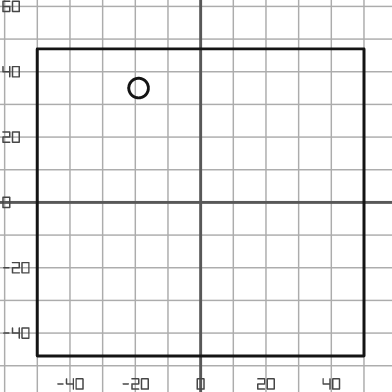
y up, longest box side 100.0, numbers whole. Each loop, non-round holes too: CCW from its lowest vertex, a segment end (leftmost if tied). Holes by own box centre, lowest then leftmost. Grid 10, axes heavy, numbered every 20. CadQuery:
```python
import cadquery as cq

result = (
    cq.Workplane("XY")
    .moveTo(-50.0, -47.0)
    .lineTo(50.0, -47.0)
    .lineTo(50.0, 47.0)
    .lineTo(-50.0, 47.0)
    .close()
    .moveTo(-19.0, 35.0)
    .circle(3.0)
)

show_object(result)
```